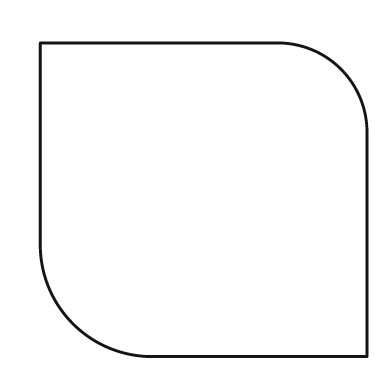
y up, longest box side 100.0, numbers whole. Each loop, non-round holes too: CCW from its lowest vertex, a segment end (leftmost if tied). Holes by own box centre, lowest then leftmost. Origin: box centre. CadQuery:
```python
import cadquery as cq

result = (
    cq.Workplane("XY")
    .moveTo(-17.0, -48.0)
    .lineTo(50.0, -48.0)
    .lineTo(50.0, 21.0)
    .threePointArc((42.0, 40.0), (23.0, 48.0))
    .lineTo(-50.0, 48.0)
    .lineTo(-50.0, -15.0)
    .threePointArc((-40.0, -38.0), (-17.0, -48.0))
    .close()
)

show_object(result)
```